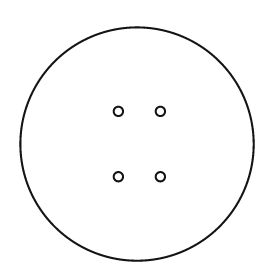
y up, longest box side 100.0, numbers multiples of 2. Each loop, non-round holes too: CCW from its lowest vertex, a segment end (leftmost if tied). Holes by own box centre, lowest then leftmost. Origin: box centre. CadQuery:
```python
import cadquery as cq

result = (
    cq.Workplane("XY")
    .moveTo(0.0, 0.0)
    .circle(50.0)
    .moveTo(-8.0, -14.0)
    .circle(2.0)
    .moveTo(10.0, -14.0)
    .circle(2.0)
    .moveTo(-8.0, 14.0)
    .circle(2.0)
    .moveTo(10.0, 14.0)
    .circle(2.0)
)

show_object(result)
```